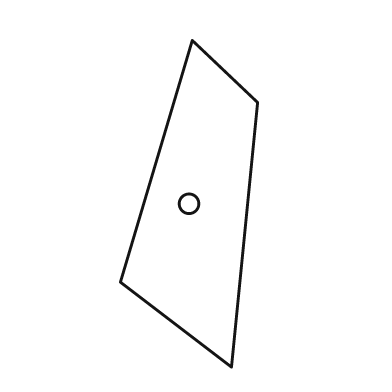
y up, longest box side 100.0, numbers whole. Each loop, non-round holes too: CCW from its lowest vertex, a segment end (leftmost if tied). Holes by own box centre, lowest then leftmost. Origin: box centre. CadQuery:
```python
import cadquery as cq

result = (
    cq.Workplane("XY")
    .moveTo(13.0, -50.0)
    .lineTo(21.0, 31.0)
    .lineTo(1.0, 50.0)
    .lineTo(-21.0, -24.0)
    .close()
    .moveTo(0.0, 0.0)
    .circle(3.0)
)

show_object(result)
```